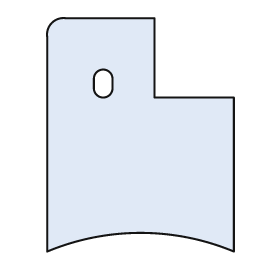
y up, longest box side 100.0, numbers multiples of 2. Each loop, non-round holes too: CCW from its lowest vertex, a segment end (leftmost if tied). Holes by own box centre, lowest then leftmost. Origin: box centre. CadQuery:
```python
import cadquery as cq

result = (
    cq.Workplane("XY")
    .moveTo(-40.0, -50.0)
    .threePointArc((0.0, -42.0), (40.0, -50.0))
    .lineTo(40.0, 16.0)
    .lineTo(6.0, 16.0)
    .lineTo(6.0, 50.0)
    .lineTo(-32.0, 50.0)
    .threePointArc((-38.0, 48.0), (-40.0, 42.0))
    .close()
    .moveTo(-20.0, 20.0)
    .threePointArc((-16.0, 16.0), (-12.0, 20.0))
    .lineTo(-12.0, 24.0)
    .threePointArc((-16.0, 28.0), (-20.0, 24.0))
    .close()
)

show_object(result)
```